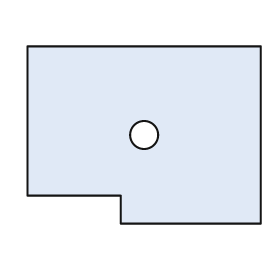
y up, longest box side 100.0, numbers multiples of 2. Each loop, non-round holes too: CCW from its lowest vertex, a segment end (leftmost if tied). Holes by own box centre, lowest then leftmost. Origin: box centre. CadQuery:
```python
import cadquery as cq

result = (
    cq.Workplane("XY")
    .moveTo(-10.0, -38.0)
    .lineTo(50.0, -38.0)
    .lineTo(50.0, 38.0)
    .lineTo(-50.0, 38.0)
    .lineTo(-50.0, -26.0)
    .lineTo(-10.0, -26.0)
    .close()
    .moveTo(0.0, 0.0)
    .circle(6.0)
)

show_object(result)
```